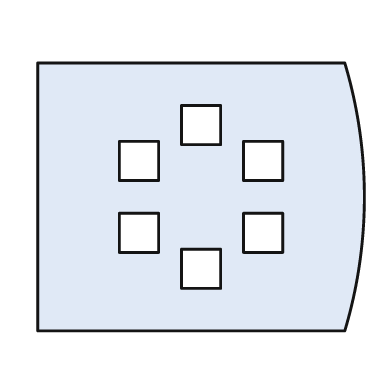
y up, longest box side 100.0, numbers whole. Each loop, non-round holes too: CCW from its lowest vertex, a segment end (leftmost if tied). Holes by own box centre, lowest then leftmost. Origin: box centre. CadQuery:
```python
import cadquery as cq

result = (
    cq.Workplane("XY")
    .moveTo(-50.0, -41.0)
    .lineTo(44.0, -41.0)
    .threePointArc((50.0, 0.0), (44.0, 41.0))
    .lineTo(-50.0, 41.0)
    .close()
    .moveTo(-6.0, -28.0)
    .lineTo(6.0, -28.0)
    .lineTo(6.0, -16.0)
    .lineTo(-6.0, -16.0)
    .close()
    .moveTo(-25.0, -17.0)
    .lineTo(-13.0, -17.0)
    .lineTo(-13.0, -5.0)
    .lineTo(-25.0, -5.0)
    .close()
    .moveTo(13.0, -17.0)
    .lineTo(25.0, -17.0)
    .lineTo(25.0, -5.0)
    .lineTo(13.0, -5.0)
    .close()
    .moveTo(-25.0, 5.0)
    .lineTo(-13.0, 5.0)
    .lineTo(-13.0, 17.0)
    .lineTo(-25.0, 17.0)
    .close()
    .moveTo(13.0, 5.0)
    .lineTo(25.0, 5.0)
    .lineTo(25.0, 17.0)
    .lineTo(13.0, 17.0)
    .close()
    .moveTo(-6.0, 16.0)
    .lineTo(6.0, 16.0)
    .lineTo(6.0, 28.0)
    .lineTo(-6.0, 28.0)
    .close()
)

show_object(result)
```